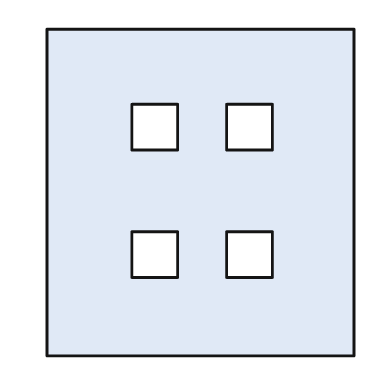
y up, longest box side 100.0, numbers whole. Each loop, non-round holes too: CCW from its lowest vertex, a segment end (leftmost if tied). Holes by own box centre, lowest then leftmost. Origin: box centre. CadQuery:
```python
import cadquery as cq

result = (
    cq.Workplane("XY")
    .moveTo(-47.0, -50.0)
    .lineTo(47.0, -50.0)
    .lineTo(47.0, 50.0)
    .lineTo(-47.0, 50.0)
    .close()
    .moveTo(-21.0, -26.0)
    .lineTo(-7.0, -26.0)
    .lineTo(-7.0, -12.0)
    .lineTo(-21.0, -12.0)
    .close()
    .moveTo(8.0, -26.0)
    .lineTo(22.0, -26.0)
    .lineTo(22.0, -12.0)
    .lineTo(8.0, -12.0)
    .close()
    .moveTo(-21.0, 13.0)
    .lineTo(-7.0, 13.0)
    .lineTo(-7.0, 27.0)
    .lineTo(-21.0, 27.0)
    .close()
    .moveTo(8.0, 13.0)
    .lineTo(22.0, 13.0)
    .lineTo(22.0, 27.0)
    .lineTo(8.0, 27.0)
    .close()
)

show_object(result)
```